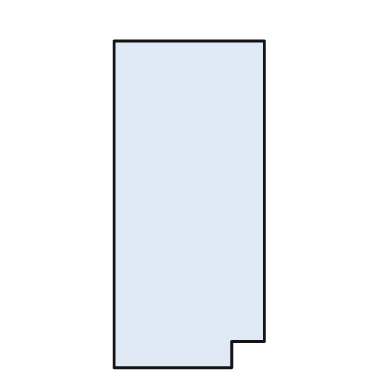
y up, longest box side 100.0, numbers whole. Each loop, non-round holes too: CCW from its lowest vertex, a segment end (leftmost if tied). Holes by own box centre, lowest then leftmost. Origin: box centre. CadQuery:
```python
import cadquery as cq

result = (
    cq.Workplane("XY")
    .moveTo(-23.0, -50.0)
    .lineTo(13.0, -50.0)
    .lineTo(13.0, -42.0)
    .lineTo(23.0, -42.0)
    .lineTo(23.0, 50.0)
    .lineTo(-23.0, 50.0)
    .close()
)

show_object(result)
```